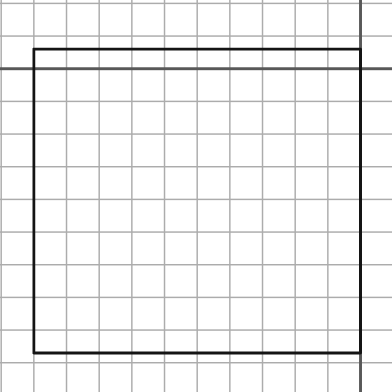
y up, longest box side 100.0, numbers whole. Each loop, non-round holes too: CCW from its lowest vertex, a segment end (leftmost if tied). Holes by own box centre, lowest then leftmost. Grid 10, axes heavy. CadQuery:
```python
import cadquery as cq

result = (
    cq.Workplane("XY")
    .moveTo(-100.0, -87.0)
    .lineTo(0.0, -87.0)
    .lineTo(0.0, 6.0)
    .lineTo(-100.0, 6.0)
    .close()
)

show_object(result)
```